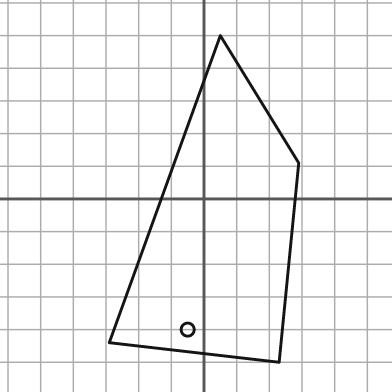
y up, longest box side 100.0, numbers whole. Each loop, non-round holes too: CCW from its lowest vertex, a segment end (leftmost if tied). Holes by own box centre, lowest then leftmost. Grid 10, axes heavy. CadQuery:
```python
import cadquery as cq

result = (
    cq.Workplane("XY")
    .moveTo(23.0, -50.0)
    .lineTo(29.0, 11.0)
    .lineTo(5.0, 50.0)
    .lineTo(-29.0, -44.0)
    .close()
    .moveTo(-5.0, -40.0)
    .circle(2.0)
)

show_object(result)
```